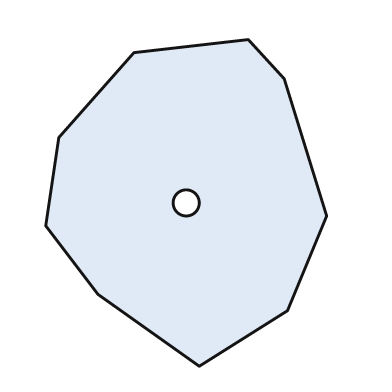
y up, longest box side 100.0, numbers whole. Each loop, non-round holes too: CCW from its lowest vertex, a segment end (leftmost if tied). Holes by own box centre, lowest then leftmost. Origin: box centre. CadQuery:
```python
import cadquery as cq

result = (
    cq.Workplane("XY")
    .moveTo(4.0, -50.0)
    .lineTo(31.0, -33.0)
    .lineTo(43.0, -4.0)
    .lineTo(30.0, 38.0)
    .lineTo(19.0, 50.0)
    .lineTo(-16.0, 46.0)
    .lineTo(-39.0, 20.0)
    .lineTo(-43.0, -7.0)
    .lineTo(-27.0, -28.0)
    .close()
    .moveTo(0.0, 0.0)
    .circle(4.0)
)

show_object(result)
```